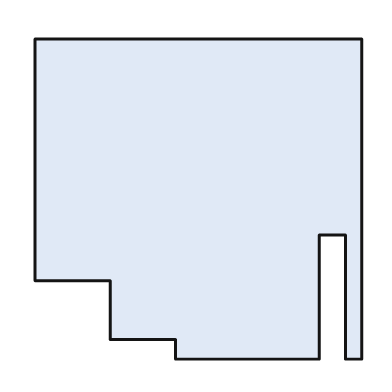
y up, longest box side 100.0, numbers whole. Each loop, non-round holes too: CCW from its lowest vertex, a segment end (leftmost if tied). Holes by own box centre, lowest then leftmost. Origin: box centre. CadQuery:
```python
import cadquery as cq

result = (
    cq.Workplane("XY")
    .moveTo(-7.0, -49.0)
    .lineTo(37.0, -49.0)
    .lineTo(37.0, -11.0)
    .lineTo(45.0, -11.0)
    .lineTo(45.0, -49.0)
    .lineTo(50.0, -49.0)
    .lineTo(50.0, 49.0)
    .lineTo(-50.0, 49.0)
    .lineTo(-50.0, -25.0)
    .lineTo(-27.0, -25.0)
    .lineTo(-27.0, -43.0)
    .lineTo(-7.0, -43.0)
    .close()
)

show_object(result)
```